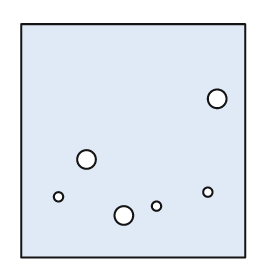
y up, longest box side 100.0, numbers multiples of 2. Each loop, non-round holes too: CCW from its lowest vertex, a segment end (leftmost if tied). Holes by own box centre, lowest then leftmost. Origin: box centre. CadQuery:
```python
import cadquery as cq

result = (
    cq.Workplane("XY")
    .moveTo(-48.0, -50.0)
    .lineTo(48.0, -50.0)
    .lineTo(48.0, 50.0)
    .lineTo(-48.0, 50.0)
    .close()
    .moveTo(-4.0, -32.0)
    .circle(4.0)
    .moveTo(10.0, -28.0)
    .circle(2.0)
    .moveTo(-32.0, -24.0)
    .circle(2.0)
    .moveTo(32.0, -22.0)
    .circle(2.0)
    .moveTo(-20.0, -8.0)
    .circle(4.0)
    .moveTo(36.0, 18.0)
    .circle(4.0)
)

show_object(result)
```